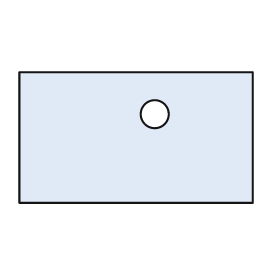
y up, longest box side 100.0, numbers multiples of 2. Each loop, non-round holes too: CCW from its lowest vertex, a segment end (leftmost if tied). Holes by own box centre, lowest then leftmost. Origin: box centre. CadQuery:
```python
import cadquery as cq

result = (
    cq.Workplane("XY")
    .moveTo(-50.0, -28.0)
    .lineTo(50.0, -28.0)
    .lineTo(50.0, 28.0)
    .lineTo(-50.0, 28.0)
    .close()
    .moveTo(8.0, 10.0)
    .circle(6.0)
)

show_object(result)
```